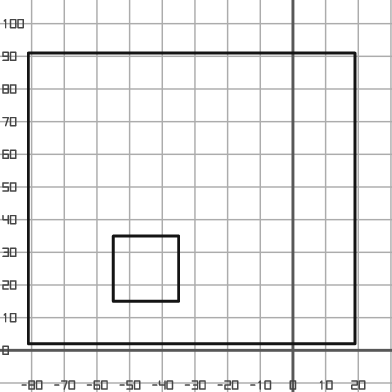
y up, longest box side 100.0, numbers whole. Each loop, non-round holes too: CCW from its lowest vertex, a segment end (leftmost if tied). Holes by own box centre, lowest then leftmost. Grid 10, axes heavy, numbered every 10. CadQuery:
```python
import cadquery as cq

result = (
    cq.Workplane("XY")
    .moveTo(-81.0, 2.0)
    .lineTo(19.0, 2.0)
    .lineTo(19.0, 91.0)
    .lineTo(-81.0, 91.0)
    .close()
    .moveTo(-55.0, 15.0)
    .lineTo(-35.0, 15.0)
    .lineTo(-35.0, 35.0)
    .lineTo(-55.0, 35.0)
    .close()
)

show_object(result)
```